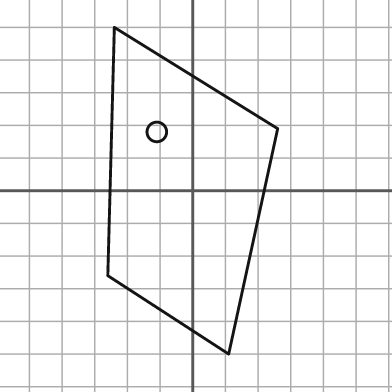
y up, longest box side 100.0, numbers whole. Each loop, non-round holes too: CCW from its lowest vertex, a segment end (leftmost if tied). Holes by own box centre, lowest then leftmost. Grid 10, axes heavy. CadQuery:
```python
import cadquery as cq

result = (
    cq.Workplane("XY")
    .moveTo(11.0, -50.0)
    .lineTo(26.0, 19.0)
    .lineTo(-24.0, 50.0)
    .lineTo(-26.0, -26.0)
    .close()
    .moveTo(-11.0, 18.0)
    .circle(3.0)
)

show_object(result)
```